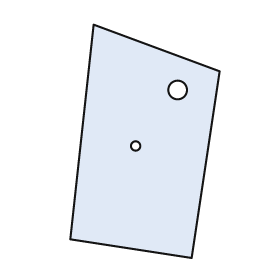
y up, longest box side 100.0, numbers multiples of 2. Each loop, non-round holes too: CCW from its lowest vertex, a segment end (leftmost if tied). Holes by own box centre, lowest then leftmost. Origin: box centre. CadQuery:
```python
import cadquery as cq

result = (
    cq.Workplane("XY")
    .moveTo(20.0, -50.0)
    .lineTo(32.0, 30.0)
    .lineTo(-22.0, 50.0)
    .lineTo(-32.0, -42.0)
    .close()
    .moveTo(-4.0, -2.0)
    .circle(2.0)
    .moveTo(14.0, 22.0)
    .circle(4.0)
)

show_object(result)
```